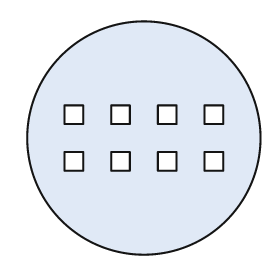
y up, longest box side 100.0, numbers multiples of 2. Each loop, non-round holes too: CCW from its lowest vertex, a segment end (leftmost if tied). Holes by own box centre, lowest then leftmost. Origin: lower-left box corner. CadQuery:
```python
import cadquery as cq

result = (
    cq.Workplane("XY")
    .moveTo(50.0, 50.0)
    .circle(50.0)
    .moveTo(16.0, 36.0)
    .lineTo(24.0, 36.0)
    .lineTo(24.0, 44.0)
    .lineTo(16.0, 44.0)
    .close()
    .moveTo(36.0, 36.0)
    .lineTo(44.0, 36.0)
    .lineTo(44.0, 44.0)
    .lineTo(36.0, 44.0)
    .close()
    .moveTo(56.0, 36.0)
    .lineTo(64.0, 36.0)
    .lineTo(64.0, 44.0)
    .lineTo(56.0, 44.0)
    .close()
    .moveTo(76.0, 36.0)
    .lineTo(84.0, 36.0)
    .lineTo(84.0, 44.0)
    .lineTo(76.0, 44.0)
    .close()
    .moveTo(16.0, 56.0)
    .lineTo(24.0, 56.0)
    .lineTo(24.0, 64.0)
    .lineTo(16.0, 64.0)
    .close()
    .moveTo(36.0, 56.0)
    .lineTo(44.0, 56.0)
    .lineTo(44.0, 64.0)
    .lineTo(36.0, 64.0)
    .close()
    .moveTo(56.0, 56.0)
    .lineTo(64.0, 56.0)
    .lineTo(64.0, 64.0)
    .lineTo(56.0, 64.0)
    .close()
    .moveTo(76.0, 56.0)
    .lineTo(84.0, 56.0)
    .lineTo(84.0, 64.0)
    .lineTo(76.0, 64.0)
    .close()
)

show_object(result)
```